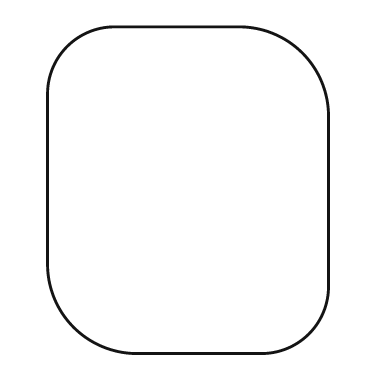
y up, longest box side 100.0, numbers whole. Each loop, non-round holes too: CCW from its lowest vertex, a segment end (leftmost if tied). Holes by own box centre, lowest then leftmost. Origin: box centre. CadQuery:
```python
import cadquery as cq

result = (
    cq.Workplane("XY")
    .moveTo(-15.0, -50.0)
    .lineTo(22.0, -50.0)
    .threePointArc((37.0, -44.0), (43.0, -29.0))
    .lineTo(43.0, 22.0)
    .threePointArc((35.0, 42.0), (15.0, 50.0))
    .lineTo(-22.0, 50.0)
    .threePointArc((-37.0, 44.0), (-43.0, 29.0))
    .lineTo(-43.0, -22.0)
    .threePointArc((-35.0, -42.0), (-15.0, -50.0))
    .close()
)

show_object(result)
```